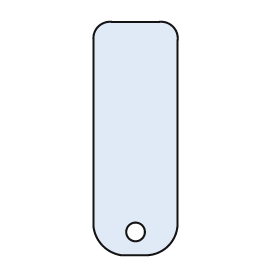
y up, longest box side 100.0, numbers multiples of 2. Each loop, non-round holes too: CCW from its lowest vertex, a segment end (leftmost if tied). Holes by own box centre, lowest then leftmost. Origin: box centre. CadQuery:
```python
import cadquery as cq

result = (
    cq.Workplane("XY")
    .moveTo(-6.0, -50.0)
    .lineTo(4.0, -50.0)
    .threePointArc((14.0, -46.0), (18.0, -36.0))
    .lineTo(18.0, 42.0)
    .threePointArc((16.0, 48.0), (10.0, 50.0))
    .lineTo(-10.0, 50.0)
    .threePointArc((-16.0, 48.0), (-18.0, 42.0))
    .lineTo(-18.0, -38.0)
    .threePointArc((-14.0, -46.0), (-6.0, -50.0))
    .close()
    .moveTo(0.0, -40.0)
    .circle(4.0)
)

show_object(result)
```